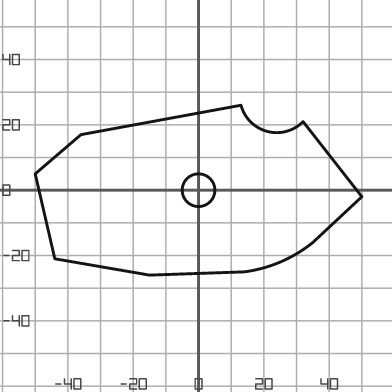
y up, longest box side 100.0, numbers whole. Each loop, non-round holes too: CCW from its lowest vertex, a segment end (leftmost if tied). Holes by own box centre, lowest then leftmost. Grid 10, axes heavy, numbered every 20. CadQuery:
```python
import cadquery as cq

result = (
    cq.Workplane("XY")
    .moveTo(-15.0, -26.0)
    .lineTo(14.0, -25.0)
    .threePointArc((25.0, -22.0), (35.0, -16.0))
    .lineTo(50.0, -2.0)
    .lineTo(32.0, 21.0)
    .threePointArc((21.0, 18.0), (13.0, 26.0))
    .lineTo(-36.0, 17.0)
    .lineTo(-50.0, 5.0)
    .lineTo(-44.0, -21.0)
    .close()
    .moveTo(0.0, 0.0)
    .circle(5.0)
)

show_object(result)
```